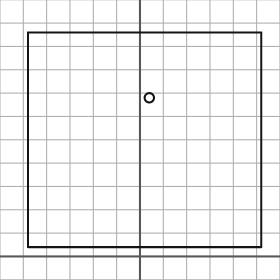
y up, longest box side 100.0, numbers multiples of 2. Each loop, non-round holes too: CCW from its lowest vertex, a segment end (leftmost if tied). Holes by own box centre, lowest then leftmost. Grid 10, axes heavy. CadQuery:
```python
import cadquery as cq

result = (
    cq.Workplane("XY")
    .moveTo(-48.0, 4.0)
    .lineTo(52.0, 4.0)
    .lineTo(52.0, 96.0)
    .lineTo(-48.0, 96.0)
    .close()
    .moveTo(4.0, 68.0)
    .circle(2.0)
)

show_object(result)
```